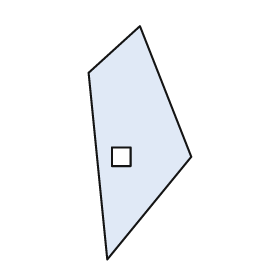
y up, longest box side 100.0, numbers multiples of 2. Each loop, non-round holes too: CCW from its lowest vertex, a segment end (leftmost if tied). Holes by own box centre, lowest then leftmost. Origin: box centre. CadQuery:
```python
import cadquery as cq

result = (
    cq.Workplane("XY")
    .moveTo(-14.0, -50.0)
    .lineTo(22.0, -6.0)
    .lineTo(0.0, 50.0)
    .lineTo(-22.0, 30.0)
    .close()
    .moveTo(-12.0, -10.0)
    .lineTo(-4.0, -10.0)
    .lineTo(-4.0, -2.0)
    .lineTo(-12.0, -2.0)
    .close()
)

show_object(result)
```